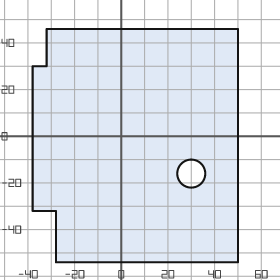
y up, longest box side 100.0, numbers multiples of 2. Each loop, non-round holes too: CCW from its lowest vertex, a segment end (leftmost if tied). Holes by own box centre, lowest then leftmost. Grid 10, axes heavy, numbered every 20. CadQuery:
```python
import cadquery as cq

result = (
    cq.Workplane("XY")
    .moveTo(-28.0, -54.0)
    .lineTo(50.0, -54.0)
    .lineTo(50.0, 46.0)
    .lineTo(-32.0, 46.0)
    .lineTo(-32.0, 30.0)
    .lineTo(-38.0, 30.0)
    .lineTo(-38.0, -32.0)
    .lineTo(-28.0, -32.0)
    .close()
    .moveTo(30.0, -16.0)
    .circle(6.0)
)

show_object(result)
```